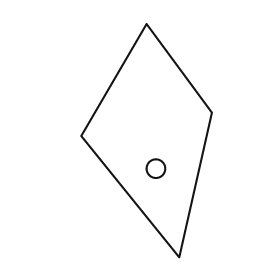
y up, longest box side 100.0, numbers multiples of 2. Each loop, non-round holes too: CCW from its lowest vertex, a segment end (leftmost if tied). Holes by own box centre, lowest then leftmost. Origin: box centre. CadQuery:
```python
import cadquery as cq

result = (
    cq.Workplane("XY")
    .moveTo(14.0, -50.0)
    .lineTo(28.0, 12.0)
    .lineTo(0.0, 50.0)
    .lineTo(-28.0, 2.0)
    .close()
    .moveTo(4.0, -12.0)
    .circle(4.0)
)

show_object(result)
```